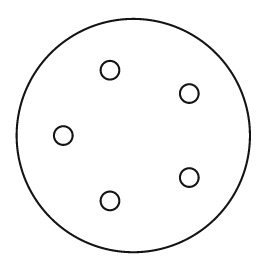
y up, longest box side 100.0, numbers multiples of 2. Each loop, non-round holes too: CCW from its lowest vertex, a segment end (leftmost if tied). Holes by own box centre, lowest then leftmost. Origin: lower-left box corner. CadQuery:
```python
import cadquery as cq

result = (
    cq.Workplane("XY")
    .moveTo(50.0, 50.0)
    .circle(50.0)
    .moveTo(40.0, 22.0)
    .circle(4.0)
    .moveTo(74.0, 32.0)
    .circle(4.0)
    .moveTo(20.0, 50.0)
    .circle(4.0)
    .moveTo(74.0, 68.0)
    .circle(4.0)
    .moveTo(40.0, 78.0)
    .circle(4.0)
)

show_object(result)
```